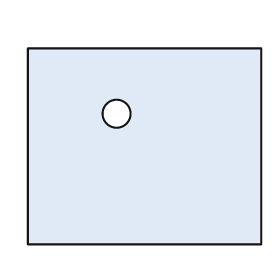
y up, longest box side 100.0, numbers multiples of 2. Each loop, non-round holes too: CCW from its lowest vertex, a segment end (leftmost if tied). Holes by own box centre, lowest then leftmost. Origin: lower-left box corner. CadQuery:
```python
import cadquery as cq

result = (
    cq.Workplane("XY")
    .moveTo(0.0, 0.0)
    .lineTo(100.0, 0.0)
    .lineTo(100.0, 84.0)
    .lineTo(0.0, 84.0)
    .close()
    .moveTo(38.0, 56.0)
    .circle(6.0)
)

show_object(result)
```